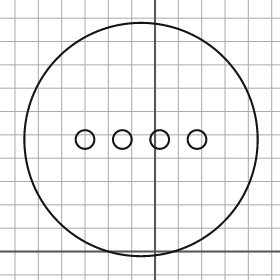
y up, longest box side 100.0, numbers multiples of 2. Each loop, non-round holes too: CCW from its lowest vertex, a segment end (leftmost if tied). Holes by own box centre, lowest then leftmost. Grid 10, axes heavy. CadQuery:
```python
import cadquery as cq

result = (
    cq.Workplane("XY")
    .moveTo(-6.0, 48.0)
    .circle(50.0)
    .moveTo(-30.0, 48.0)
    .circle(4.0)
    .moveTo(-14.0, 48.0)
    .circle(4.0)
    .moveTo(2.0, 48.0)
    .circle(4.0)
    .moveTo(18.0, 48.0)
    .circle(4.0)
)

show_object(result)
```